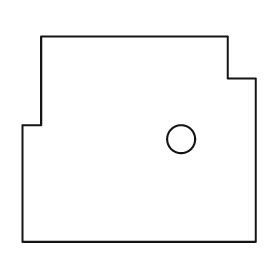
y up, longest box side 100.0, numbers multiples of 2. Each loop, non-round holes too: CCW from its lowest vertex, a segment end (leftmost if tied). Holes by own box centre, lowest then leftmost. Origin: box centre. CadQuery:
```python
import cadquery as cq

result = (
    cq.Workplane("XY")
    .moveTo(-50.0, -44.0)
    .lineTo(50.0, -44.0)
    .lineTo(50.0, 26.0)
    .lineTo(38.0, 26.0)
    .lineTo(38.0, 44.0)
    .lineTo(-42.0, 44.0)
    .lineTo(-42.0, 6.0)
    .lineTo(-50.0, 6.0)
    .close()
    .moveTo(18.0, 0.0)
    .circle(6.0)
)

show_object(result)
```